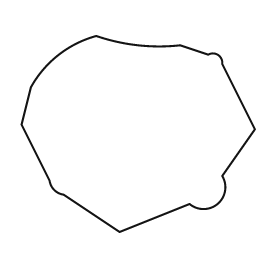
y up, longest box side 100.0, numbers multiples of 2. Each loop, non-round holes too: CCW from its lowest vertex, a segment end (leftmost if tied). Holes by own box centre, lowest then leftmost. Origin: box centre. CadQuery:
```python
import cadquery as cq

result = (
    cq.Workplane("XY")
    .moveTo(-8.0, -42.0)
    .lineTo(22.0, -30.0)
    .threePointArc((34.0, -30.0), (36.0, -18.0))
    .lineTo(50.0, 2.0)
    .lineTo(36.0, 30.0)
    .threePointArc((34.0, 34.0), (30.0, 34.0))
    .lineTo(18.0, 38.0)
    .threePointArc((0.0, 38.0), (-18.0, 42.0))
    .threePointArc((-34.0, 34.0), (-46.0, 20.0))
    .lineTo(-50.0, 4.0)
    .lineTo(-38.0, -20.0)
    .threePointArc((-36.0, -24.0), (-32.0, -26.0))
    .close()
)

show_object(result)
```